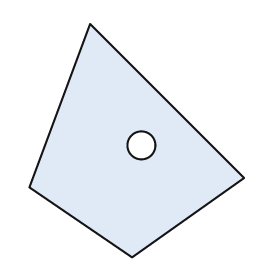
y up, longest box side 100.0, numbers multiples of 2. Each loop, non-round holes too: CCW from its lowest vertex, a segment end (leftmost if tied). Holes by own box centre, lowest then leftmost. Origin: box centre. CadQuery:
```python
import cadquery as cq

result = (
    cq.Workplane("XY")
    .moveTo(-2.0, -50.0)
    .lineTo(46.0, -16.0)
    .lineTo(-20.0, 50.0)
    .lineTo(-46.0, -20.0)
    .close()
    .moveTo(2.0, -2.0)
    .circle(6.0)
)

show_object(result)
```